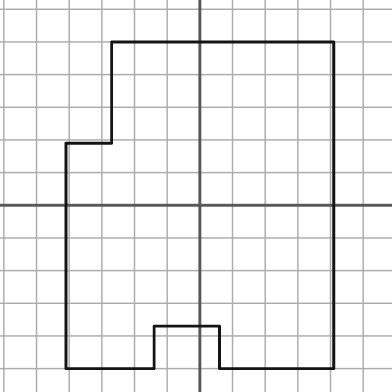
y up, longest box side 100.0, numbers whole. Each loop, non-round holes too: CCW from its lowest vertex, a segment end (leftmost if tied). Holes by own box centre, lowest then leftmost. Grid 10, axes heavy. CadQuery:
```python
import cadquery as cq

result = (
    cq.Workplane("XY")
    .moveTo(-41.0, -50.0)
    .lineTo(-14.0, -50.0)
    .lineTo(-14.0, -37.0)
    .lineTo(6.0, -37.0)
    .lineTo(6.0, -50.0)
    .lineTo(41.0, -50.0)
    .lineTo(41.0, 50.0)
    .lineTo(-27.0, 50.0)
    .lineTo(-27.0, 19.0)
    .lineTo(-41.0, 19.0)
    .close()
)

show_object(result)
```